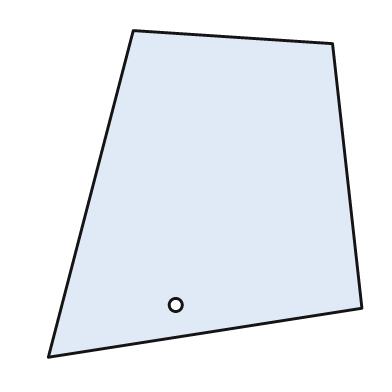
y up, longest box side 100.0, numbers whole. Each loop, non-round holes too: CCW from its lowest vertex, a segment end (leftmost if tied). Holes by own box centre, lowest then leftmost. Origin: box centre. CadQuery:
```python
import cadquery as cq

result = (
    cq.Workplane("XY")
    .moveTo(-48.0, -50.0)
    .lineTo(48.0, -35.0)
    .lineTo(39.0, 46.0)
    .lineTo(-22.0, 50.0)
    .close()
    .moveTo(-9.0, -34.0)
    .circle(2.0)
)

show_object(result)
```